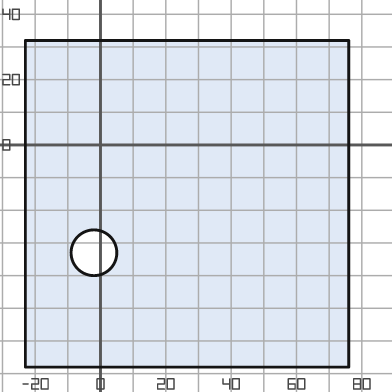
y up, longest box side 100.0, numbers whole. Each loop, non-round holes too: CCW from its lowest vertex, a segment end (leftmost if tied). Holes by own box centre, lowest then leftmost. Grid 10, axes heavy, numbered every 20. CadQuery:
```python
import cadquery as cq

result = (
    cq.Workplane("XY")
    .moveTo(-23.0, -68.0)
    .lineTo(76.0, -68.0)
    .lineTo(76.0, 32.0)
    .lineTo(-23.0, 32.0)
    .close()
    .moveTo(-2.0, -33.0)
    .circle(7.0)
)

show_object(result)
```